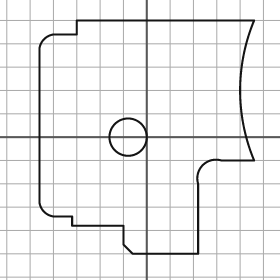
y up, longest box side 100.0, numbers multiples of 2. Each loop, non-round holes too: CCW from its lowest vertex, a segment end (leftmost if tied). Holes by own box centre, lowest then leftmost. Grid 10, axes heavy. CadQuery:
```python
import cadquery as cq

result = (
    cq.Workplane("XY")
    .moveTo(-6.0, -50.0)
    .lineTo(22.0, -50.0)
    .lineTo(22.0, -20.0)
    .threePointArc((24.0, -12.0), (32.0, -10.0))
    .lineTo(46.0, -10.0)
    .threePointArc((40.0, 20.0), (46.0, 50.0))
    .lineTo(-30.0, 50.0)
    .lineTo(-30.0, 44.0)
    .lineTo(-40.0, 44.0)
    .threePointArc((-44.0, 42.0), (-46.0, 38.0))
    .lineTo(-46.0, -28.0)
    .threePointArc((-44.0, -32.0), (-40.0, -34.0))
    .lineTo(-32.0, -34.0)
    .lineTo(-32.0, -38.0)
    .lineTo(-10.0, -38.0)
    .lineTo(-10.0, -46.0)
    .close()
    .moveTo(-8.0, 0.0)
    .circle(8.0)
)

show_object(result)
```